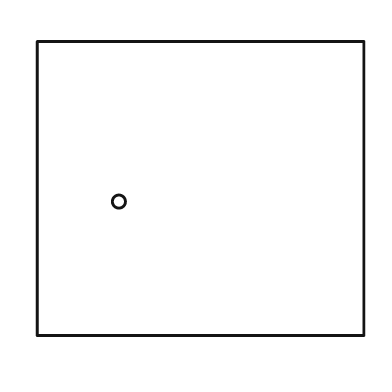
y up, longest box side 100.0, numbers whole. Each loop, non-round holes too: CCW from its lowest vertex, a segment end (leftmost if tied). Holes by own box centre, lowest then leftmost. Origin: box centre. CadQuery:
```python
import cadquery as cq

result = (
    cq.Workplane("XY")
    .moveTo(-50.0, -45.0)
    .lineTo(50.0, -45.0)
    .lineTo(50.0, 45.0)
    .lineTo(-50.0, 45.0)
    .close()
    .moveTo(-25.0, -4.0)
    .circle(2.0)
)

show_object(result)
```